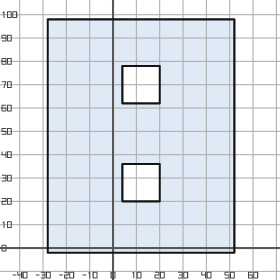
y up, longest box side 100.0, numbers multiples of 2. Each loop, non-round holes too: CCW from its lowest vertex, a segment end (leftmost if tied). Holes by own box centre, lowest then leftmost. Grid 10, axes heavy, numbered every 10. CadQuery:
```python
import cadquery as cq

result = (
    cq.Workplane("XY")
    .moveTo(-28.0, -2.0)
    .lineTo(52.0, -2.0)
    .lineTo(52.0, 98.0)
    .lineTo(-28.0, 98.0)
    .close()
    .moveTo(4.0, 20.0)
    .lineTo(20.0, 20.0)
    .lineTo(20.0, 36.0)
    .lineTo(4.0, 36.0)
    .close()
    .moveTo(4.0, 62.0)
    .lineTo(20.0, 62.0)
    .lineTo(20.0, 78.0)
    .lineTo(4.0, 78.0)
    .close()
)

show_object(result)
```